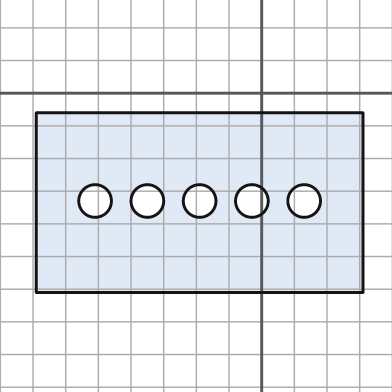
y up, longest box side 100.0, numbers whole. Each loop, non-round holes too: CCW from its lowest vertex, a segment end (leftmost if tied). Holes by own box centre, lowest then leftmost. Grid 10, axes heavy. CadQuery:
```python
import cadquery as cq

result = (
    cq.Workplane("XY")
    .moveTo(-69.0, -61.0)
    .lineTo(31.0, -61.0)
    .lineTo(31.0, -6.0)
    .lineTo(-69.0, -6.0)
    .close()
    .moveTo(-51.0, -33.0)
    .circle(5.0)
    .moveTo(-35.0, -33.0)
    .circle(5.0)
    .moveTo(-19.0, -33.0)
    .circle(5.0)
    .moveTo(-3.0, -33.0)
    .circle(5.0)
    .moveTo(13.0, -33.0)
    .circle(5.0)
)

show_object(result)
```